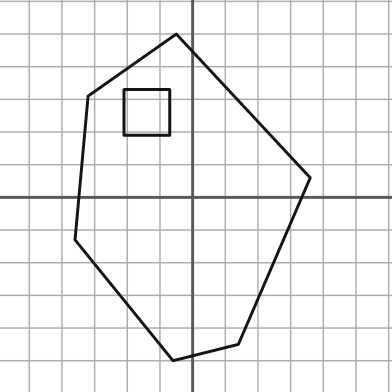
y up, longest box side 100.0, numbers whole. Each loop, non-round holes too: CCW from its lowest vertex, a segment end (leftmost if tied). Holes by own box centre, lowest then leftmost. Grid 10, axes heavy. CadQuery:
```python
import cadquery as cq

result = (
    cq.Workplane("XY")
    .moveTo(-6.0, -50.0)
    .lineTo(14.0, -45.0)
    .lineTo(36.0, 6.0)
    .lineTo(-5.0, 50.0)
    .lineTo(-32.0, 31.0)
    .lineTo(-36.0, -13.0)
    .close()
    .moveTo(-21.0, 19.0)
    .lineTo(-7.0, 19.0)
    .lineTo(-7.0, 33.0)
    .lineTo(-21.0, 33.0)
    .close()
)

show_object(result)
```